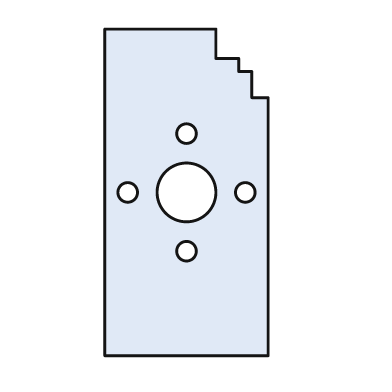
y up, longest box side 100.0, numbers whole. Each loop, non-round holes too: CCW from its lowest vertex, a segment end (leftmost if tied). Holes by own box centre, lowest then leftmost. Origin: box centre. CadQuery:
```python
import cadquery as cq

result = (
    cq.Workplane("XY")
    .moveTo(-25.0, -50.0)
    .lineTo(25.0, -50.0)
    .lineTo(25.0, 29.0)
    .lineTo(20.0, 29.0)
    .lineTo(20.0, 37.0)
    .lineTo(16.0, 37.0)
    .lineTo(16.0, 41.0)
    .lineTo(9.0, 41.0)
    .lineTo(9.0, 50.0)
    .lineTo(-25.0, 50.0)
    .close()
    .moveTo(0.0, -18.0)
    .circle(3.0)
    .moveTo(-18.0, 0.0)
    .circle(3.0)
    .moveTo(0.0, 0.0)
    .circle(9.0)
    .moveTo(18.0, 0.0)
    .circle(3.0)
    .moveTo(0.0, 18.0)
    .circle(3.0)
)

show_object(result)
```